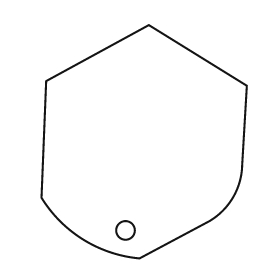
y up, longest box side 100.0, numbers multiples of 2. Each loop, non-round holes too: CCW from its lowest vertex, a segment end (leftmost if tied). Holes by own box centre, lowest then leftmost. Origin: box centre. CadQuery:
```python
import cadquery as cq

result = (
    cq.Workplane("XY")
    .moveTo(-2.0, -50.0)
    .lineTo(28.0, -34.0)
    .threePointArc((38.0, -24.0), (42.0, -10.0))
    .lineTo(44.0, 24.0)
    .lineTo(2.0, 50.0)
    .lineTo(-42.0, 26.0)
    .lineTo(-44.0, -24.0)
    .threePointArc((-26.0, -42.0), (-2.0, -50.0))
    .close()
    .moveTo(-8.0, -38.0)
    .circle(4.0)
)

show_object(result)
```